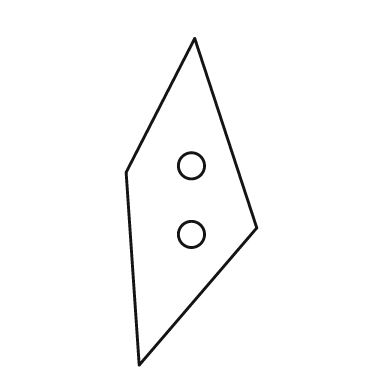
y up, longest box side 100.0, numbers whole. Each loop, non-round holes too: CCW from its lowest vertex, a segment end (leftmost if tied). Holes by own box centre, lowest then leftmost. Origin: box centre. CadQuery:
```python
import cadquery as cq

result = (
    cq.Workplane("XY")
    .moveTo(-16.0, -50.0)
    .lineTo(20.0, -8.0)
    .lineTo(1.0, 50.0)
    .lineTo(-20.0, 9.0)
    .close()
    .moveTo(0.0, -10.0)
    .circle(4.0)
    .moveTo(0.0, 11.0)
    .circle(4.0)
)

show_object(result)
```